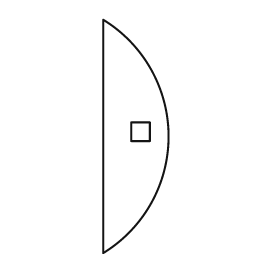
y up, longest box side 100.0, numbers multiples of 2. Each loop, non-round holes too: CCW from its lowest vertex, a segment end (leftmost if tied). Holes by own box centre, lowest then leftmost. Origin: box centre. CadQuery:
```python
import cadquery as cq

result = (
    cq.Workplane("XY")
    .moveTo(-14.0, -50.0)
    .threePointArc((14.0, 0.0), (-14.0, 50.0))
    .close()
    .moveTo(-2.0, -2.0)
    .lineTo(6.0, -2.0)
    .lineTo(6.0, 6.0)
    .lineTo(-2.0, 6.0)
    .close()
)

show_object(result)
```